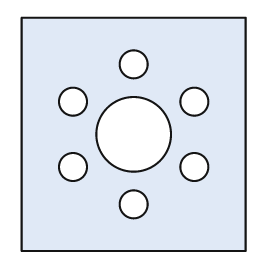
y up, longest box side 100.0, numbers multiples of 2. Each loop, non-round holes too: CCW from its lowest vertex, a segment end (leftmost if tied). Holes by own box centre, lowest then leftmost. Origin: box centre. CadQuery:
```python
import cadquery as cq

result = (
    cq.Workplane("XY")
    .moveTo(-48.0, -50.0)
    .lineTo(48.0, -50.0)
    .lineTo(48.0, 50.0)
    .lineTo(-48.0, 50.0)
    .close()
    .moveTo(0.0, -30.0)
    .circle(6.0)
    .moveTo(-26.0, -14.0)
    .circle(6.0)
    .moveTo(26.0, -14.0)
    .circle(6.0)
    .moveTo(0.0, 0.0)
    .circle(16.0)
    .moveTo(-26.0, 14.0)
    .circle(6.0)
    .moveTo(26.0, 14.0)
    .circle(6.0)
    .moveTo(0.0, 30.0)
    .circle(6.0)
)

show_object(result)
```